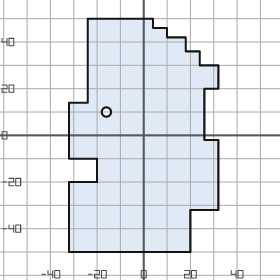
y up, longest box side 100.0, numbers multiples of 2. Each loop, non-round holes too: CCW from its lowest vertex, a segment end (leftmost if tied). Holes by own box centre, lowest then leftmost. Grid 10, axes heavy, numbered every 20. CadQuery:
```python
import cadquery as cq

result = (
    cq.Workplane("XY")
    .moveTo(-32.0, -50.0)
    .lineTo(20.0, -50.0)
    .lineTo(20.0, -32.0)
    .lineTo(32.0, -32.0)
    .lineTo(32.0, -2.0)
    .lineTo(26.0, -2.0)
    .lineTo(26.0, 20.0)
    .lineTo(32.0, 20.0)
    .lineTo(32.0, 30.0)
    .lineTo(24.0, 30.0)
    .lineTo(24.0, 36.0)
    .lineTo(18.0, 36.0)
    .lineTo(18.0, 42.0)
    .lineTo(10.0, 42.0)
    .lineTo(10.0, 46.0)
    .lineTo(4.0, 46.0)
    .lineTo(4.0, 50.0)
    .lineTo(-24.0, 50.0)
    .lineTo(-24.0, 14.0)
    .lineTo(-32.0, 14.0)
    .lineTo(-32.0, -10.0)
    .lineTo(-20.0, -10.0)
    .lineTo(-20.0, -20.0)
    .lineTo(-32.0, -20.0)
    .close()
    .moveTo(-16.0, 10.0)
    .circle(2.0)
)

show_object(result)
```